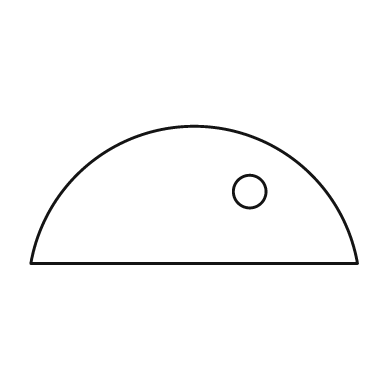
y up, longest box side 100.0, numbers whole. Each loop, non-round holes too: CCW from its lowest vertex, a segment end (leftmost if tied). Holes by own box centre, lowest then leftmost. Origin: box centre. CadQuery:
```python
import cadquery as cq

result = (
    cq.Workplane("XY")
    .moveTo(-50.0, -21.0)
    .lineTo(50.0, -21.0)
    .threePointArc((0.0, 21.0), (-50.0, -21.0))
    .close()
    .moveTo(17.0, 1.0)
    .circle(5.0)
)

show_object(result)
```